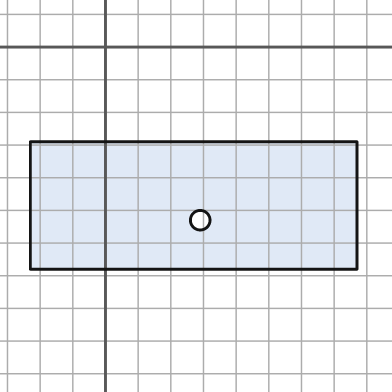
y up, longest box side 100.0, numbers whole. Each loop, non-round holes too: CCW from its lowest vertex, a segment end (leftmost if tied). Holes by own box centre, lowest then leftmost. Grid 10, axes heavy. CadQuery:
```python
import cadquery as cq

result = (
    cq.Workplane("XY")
    .moveTo(-23.0, -68.0)
    .lineTo(77.0, -68.0)
    .lineTo(77.0, -29.0)
    .lineTo(-23.0, -29.0)
    .close()
    .moveTo(29.0, -53.0)
    .circle(3.0)
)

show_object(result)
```